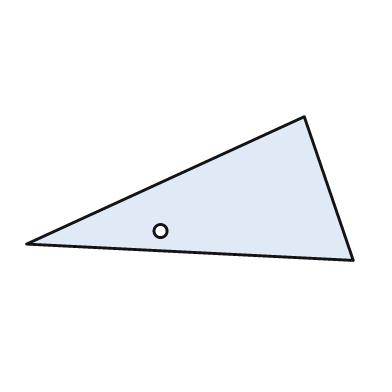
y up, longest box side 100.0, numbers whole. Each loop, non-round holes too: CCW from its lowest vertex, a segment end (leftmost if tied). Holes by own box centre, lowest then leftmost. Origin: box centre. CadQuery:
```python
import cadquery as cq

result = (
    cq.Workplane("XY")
    .moveTo(50.0, -22.0)
    .lineTo(35.0, 22.0)
    .lineTo(-50.0, -17.0)
    .close()
    .moveTo(-9.0, -13.0)
    .circle(2.0)
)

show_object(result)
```